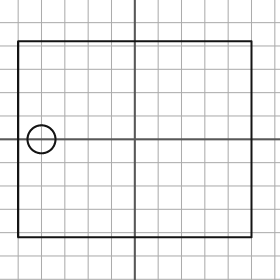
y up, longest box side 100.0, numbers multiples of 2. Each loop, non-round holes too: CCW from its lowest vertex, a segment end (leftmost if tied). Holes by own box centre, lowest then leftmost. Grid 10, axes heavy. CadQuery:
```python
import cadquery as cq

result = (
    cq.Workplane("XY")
    .moveTo(-50.0, -42.0)
    .lineTo(50.0, -42.0)
    .lineTo(50.0, 42.0)
    .lineTo(-50.0, 42.0)
    .close()
    .moveTo(-40.0, 0.0)
    .circle(6.0)
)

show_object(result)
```